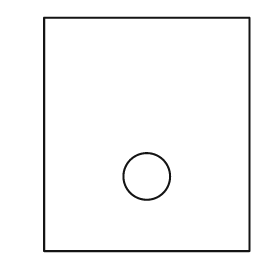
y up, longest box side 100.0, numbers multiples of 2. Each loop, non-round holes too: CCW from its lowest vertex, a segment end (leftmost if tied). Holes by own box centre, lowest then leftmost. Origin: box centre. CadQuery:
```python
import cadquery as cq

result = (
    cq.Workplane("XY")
    .moveTo(-44.0, -50.0)
    .lineTo(44.0, -50.0)
    .lineTo(44.0, 50.0)
    .lineTo(-44.0, 50.0)
    .close()
    .moveTo(0.0, -18.0)
    .circle(10.0)
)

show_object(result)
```